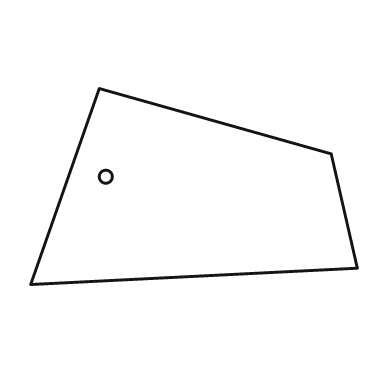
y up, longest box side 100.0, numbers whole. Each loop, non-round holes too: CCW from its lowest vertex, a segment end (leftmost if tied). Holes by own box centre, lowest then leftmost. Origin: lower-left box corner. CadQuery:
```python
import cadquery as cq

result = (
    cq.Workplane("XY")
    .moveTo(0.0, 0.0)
    .lineTo(100.0, 5.0)
    .lineTo(92.0, 40.0)
    .lineTo(21.0, 60.0)
    .close()
    .moveTo(23.0, 33.0)
    .circle(2.0)
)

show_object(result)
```